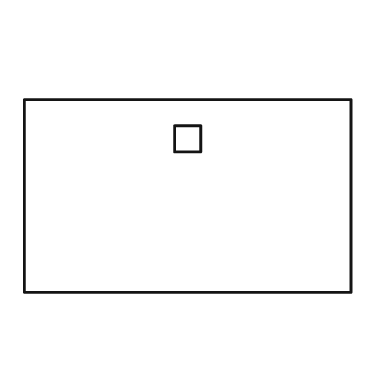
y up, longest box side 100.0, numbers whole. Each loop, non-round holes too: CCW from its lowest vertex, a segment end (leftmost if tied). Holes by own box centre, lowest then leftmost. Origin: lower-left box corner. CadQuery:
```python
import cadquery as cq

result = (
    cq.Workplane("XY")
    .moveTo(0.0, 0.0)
    .lineTo(100.0, 0.0)
    .lineTo(100.0, 59.0)
    .lineTo(0.0, 59.0)
    .close()
    .moveTo(46.0, 43.0)
    .lineTo(54.0, 43.0)
    .lineTo(54.0, 51.0)
    .lineTo(46.0, 51.0)
    .close()
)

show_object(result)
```